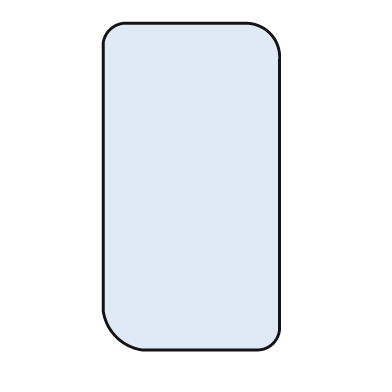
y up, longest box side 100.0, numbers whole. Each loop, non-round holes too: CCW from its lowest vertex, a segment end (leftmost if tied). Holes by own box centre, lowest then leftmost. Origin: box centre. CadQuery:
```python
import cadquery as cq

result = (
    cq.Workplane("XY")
    .moveTo(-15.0, -50.0)
    .lineTo(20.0, -50.0)
    .threePointArc((25.0, -48.0), (27.0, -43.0))
    .lineTo(27.0, 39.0)
    .threePointArc((24.0, 47.0), (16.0, 50.0))
    .lineTo(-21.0, 50.0)
    .threePointArc((-25.0, 48.0), (-27.0, 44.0))
    .lineTo(-27.0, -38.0)
    .threePointArc((-23.0, -46.0), (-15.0, -50.0))
    .close()
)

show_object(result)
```